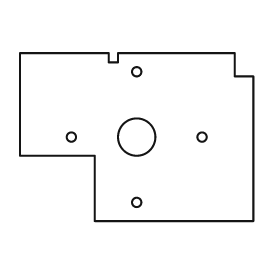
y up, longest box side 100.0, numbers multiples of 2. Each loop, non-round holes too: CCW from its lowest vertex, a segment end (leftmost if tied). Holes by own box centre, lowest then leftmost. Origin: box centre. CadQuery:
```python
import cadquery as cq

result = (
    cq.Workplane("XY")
    .moveTo(-18.0, -36.0)
    .lineTo(50.0, -36.0)
    .lineTo(50.0, 26.0)
    .lineTo(42.0, 26.0)
    .lineTo(42.0, 36.0)
    .lineTo(-8.0, 36.0)
    .lineTo(-8.0, 32.0)
    .lineTo(-12.0, 32.0)
    .lineTo(-12.0, 36.0)
    .lineTo(-50.0, 36.0)
    .lineTo(-50.0, -8.0)
    .lineTo(-18.0, -8.0)
    .close()
    .moveTo(0.0, -28.0)
    .circle(2.0)
    .moveTo(-28.0, 0.0)
    .circle(2.0)
    .moveTo(0.0, 0.0)
    .circle(8.0)
    .moveTo(28.0, 0.0)
    .circle(2.0)
    .moveTo(0.0, 28.0)
    .circle(2.0)
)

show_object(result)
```